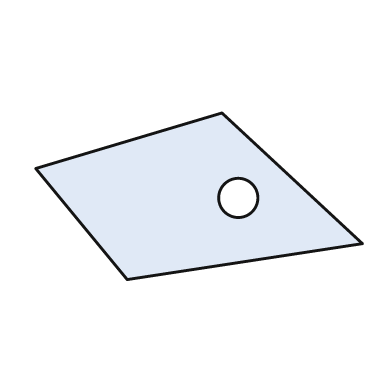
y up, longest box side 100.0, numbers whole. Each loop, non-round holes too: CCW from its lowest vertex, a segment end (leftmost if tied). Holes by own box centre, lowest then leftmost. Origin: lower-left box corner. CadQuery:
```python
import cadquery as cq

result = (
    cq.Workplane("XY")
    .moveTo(28.0, 0.0)
    .lineTo(100.0, 11.0)
    .lineTo(57.0, 51.0)
    .lineTo(0.0, 34.0)
    .close()
    .moveTo(62.0, 25.0)
    .circle(6.0)
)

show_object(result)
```